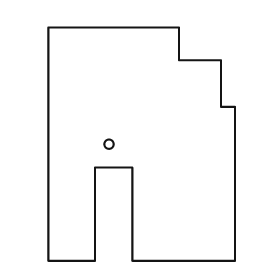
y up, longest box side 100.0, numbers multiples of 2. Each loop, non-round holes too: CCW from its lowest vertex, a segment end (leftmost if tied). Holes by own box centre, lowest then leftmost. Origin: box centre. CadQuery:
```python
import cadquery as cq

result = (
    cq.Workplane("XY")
    .moveTo(-40.0, -50.0)
    .lineTo(-20.0, -50.0)
    .lineTo(-20.0, -10.0)
    .lineTo(-4.0, -10.0)
    .lineTo(-4.0, -50.0)
    .lineTo(40.0, -50.0)
    .lineTo(40.0, 16.0)
    .lineTo(34.0, 16.0)
    .lineTo(34.0, 36.0)
    .lineTo(16.0, 36.0)
    .lineTo(16.0, 50.0)
    .lineTo(-40.0, 50.0)
    .close()
    .moveTo(-14.0, 0.0)
    .circle(2.0)
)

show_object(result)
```